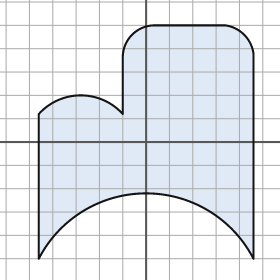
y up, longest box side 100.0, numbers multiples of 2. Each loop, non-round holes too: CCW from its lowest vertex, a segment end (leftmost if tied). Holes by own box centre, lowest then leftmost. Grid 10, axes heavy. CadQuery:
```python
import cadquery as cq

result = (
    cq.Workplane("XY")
    .moveTo(-46.0, -50.0)
    .threePointArc((0.0, -22.0), (46.0, -50.0))
    .lineTo(46.0, 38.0)
    .threePointArc((42.0, 46.0), (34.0, 50.0))
    .lineTo(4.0, 50.0)
    .threePointArc((-6.0, 46.0), (-10.0, 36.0))
    .lineTo(-10.0, 12.0)
    .threePointArc((-28.0, 20.0), (-46.0, 12.0))
    .close()
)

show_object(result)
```